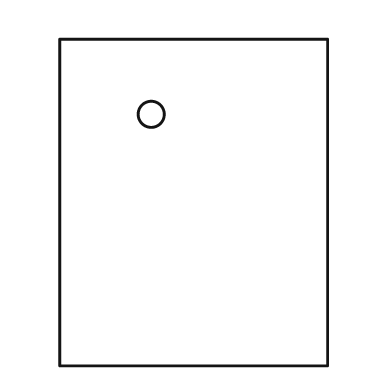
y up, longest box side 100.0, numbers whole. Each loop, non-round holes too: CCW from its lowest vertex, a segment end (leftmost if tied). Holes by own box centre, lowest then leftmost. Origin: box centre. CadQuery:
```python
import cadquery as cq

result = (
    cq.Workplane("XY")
    .moveTo(-41.0, -50.0)
    .lineTo(41.0, -50.0)
    .lineTo(41.0, 50.0)
    .lineTo(-41.0, 50.0)
    .close()
    .moveTo(-13.0, 27.0)
    .circle(4.0)
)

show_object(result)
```